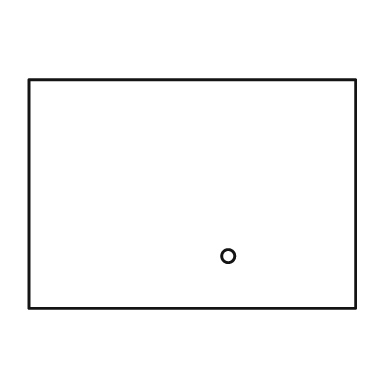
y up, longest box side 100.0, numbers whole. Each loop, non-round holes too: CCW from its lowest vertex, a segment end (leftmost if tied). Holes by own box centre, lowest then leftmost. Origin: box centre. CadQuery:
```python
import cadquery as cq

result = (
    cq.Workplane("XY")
    .moveTo(-50.0, -35.0)
    .lineTo(50.0, -35.0)
    .lineTo(50.0, 35.0)
    .lineTo(-50.0, 35.0)
    .close()
    .moveTo(11.0, -19.0)
    .circle(2.0)
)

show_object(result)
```